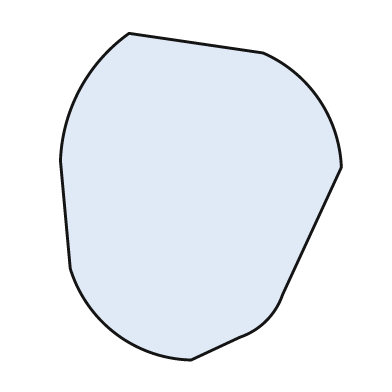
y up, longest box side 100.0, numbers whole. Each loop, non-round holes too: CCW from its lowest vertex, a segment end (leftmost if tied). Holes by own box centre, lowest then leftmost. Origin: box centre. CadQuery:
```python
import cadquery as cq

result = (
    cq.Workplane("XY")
    .moveTo(-3.0, -50.0)
    .lineTo(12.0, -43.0)
    .threePointArc((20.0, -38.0), (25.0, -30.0))
    .lineTo(43.0, 9.0)
    .threePointArc((36.0, 30.0), (19.0, 44.0))
    .lineTo(-22.0, 50.0)
    .threePointArc((-37.0, 33.0), (-43.0, 11.0))
    .lineTo(-40.0, -22.0)
    .threePointArc((-26.0, -42.0), (-3.0, -50.0))
    .close()
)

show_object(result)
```